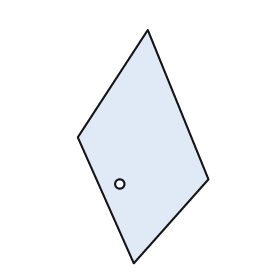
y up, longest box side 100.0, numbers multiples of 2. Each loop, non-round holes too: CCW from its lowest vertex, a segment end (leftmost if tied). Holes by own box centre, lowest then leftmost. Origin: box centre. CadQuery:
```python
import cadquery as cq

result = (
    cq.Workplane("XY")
    .moveTo(-4.0, -50.0)
    .lineTo(28.0, -14.0)
    .lineTo(2.0, 50.0)
    .lineTo(-28.0, 4.0)
    .close()
    .moveTo(-10.0, -16.0)
    .circle(2.0)
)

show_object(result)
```